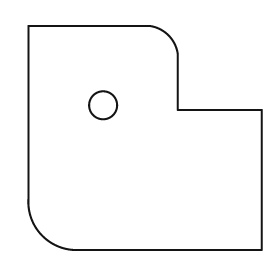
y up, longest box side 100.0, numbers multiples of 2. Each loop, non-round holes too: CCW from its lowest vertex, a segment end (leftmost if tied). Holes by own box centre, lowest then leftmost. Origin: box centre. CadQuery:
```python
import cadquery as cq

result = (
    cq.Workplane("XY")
    .moveTo(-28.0, -48.0)
    .lineTo(50.0, -48.0)
    .lineTo(50.0, 12.0)
    .lineTo(14.0, 12.0)
    .lineTo(14.0, 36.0)
    .threePointArc((10.0, 44.0), (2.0, 48.0))
    .lineTo(-50.0, 48.0)
    .lineTo(-50.0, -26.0)
    .threePointArc((-44.0, -42.0), (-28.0, -48.0))
    .close()
    .moveTo(-18.0, 14.0)
    .circle(6.0)
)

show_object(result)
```